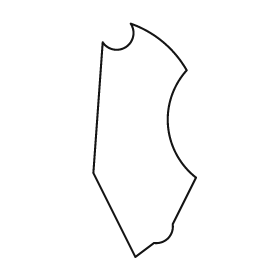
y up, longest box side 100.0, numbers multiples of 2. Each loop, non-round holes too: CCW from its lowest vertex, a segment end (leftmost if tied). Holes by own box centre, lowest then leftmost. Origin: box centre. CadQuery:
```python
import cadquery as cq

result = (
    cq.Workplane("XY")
    .moveTo(-4.0, -50.0)
    .lineTo(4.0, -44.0)
    .threePointArc((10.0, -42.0), (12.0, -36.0))
    .lineTo(22.0, -16.0)
    .threePointArc((10.0, 6.0), (18.0, 30.0))
    .threePointArc((8.0, 42.0), (-6.0, 50.0))
    .threePointArc((-8.0, 40.0), (-18.0, 42.0))
    .lineTo(-22.0, -14.0)
    .close()
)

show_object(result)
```